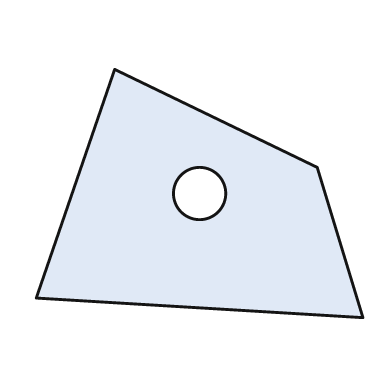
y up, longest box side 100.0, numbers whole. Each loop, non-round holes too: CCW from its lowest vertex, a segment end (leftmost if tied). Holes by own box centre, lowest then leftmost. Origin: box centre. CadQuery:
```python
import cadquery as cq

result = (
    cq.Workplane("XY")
    .moveTo(50.0, -38.0)
    .lineTo(36.0, 8.0)
    .lineTo(-26.0, 38.0)
    .lineTo(-50.0, -32.0)
    .close()
    .moveTo(0.0, 0.0)
    .circle(8.0)
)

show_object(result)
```